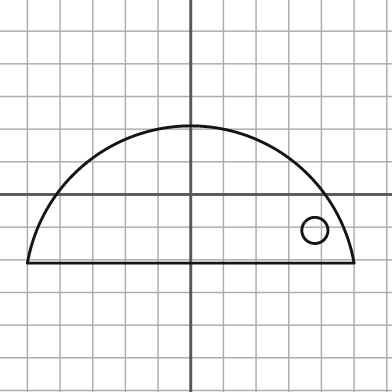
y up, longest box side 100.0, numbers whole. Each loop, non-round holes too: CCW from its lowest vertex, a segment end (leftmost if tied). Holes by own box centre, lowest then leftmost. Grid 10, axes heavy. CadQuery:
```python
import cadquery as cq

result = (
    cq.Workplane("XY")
    .moveTo(-50.0, -21.0)
    .lineTo(50.0, -21.0)
    .threePointArc((0.0, 21.0), (-50.0, -21.0))
    .close()
    .moveTo(38.0, -11.0)
    .circle(4.0)
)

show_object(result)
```